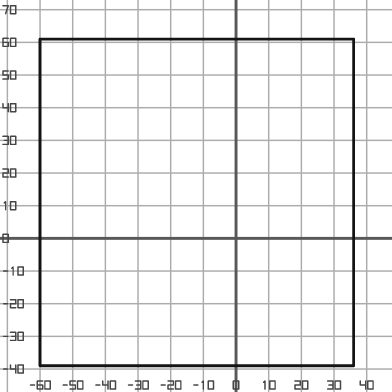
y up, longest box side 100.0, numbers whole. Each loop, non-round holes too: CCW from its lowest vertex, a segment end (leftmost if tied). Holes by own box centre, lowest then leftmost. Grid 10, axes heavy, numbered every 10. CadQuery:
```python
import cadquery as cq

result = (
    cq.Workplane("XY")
    .moveTo(-60.0, -39.0)
    .lineTo(36.0, -39.0)
    .lineTo(36.0, 61.0)
    .lineTo(-60.0, 61.0)
    .close()
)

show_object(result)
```